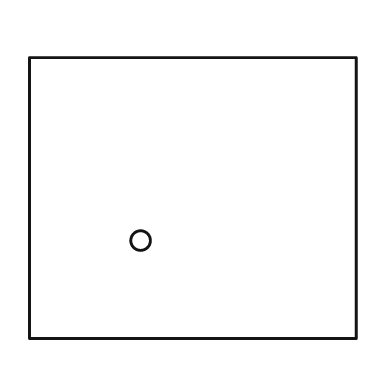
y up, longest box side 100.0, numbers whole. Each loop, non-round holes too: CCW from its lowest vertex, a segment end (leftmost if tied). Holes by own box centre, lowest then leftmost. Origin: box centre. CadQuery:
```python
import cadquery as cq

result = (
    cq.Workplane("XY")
    .moveTo(-50.0, -43.0)
    .lineTo(50.0, -43.0)
    .lineTo(50.0, 43.0)
    .lineTo(-50.0, 43.0)
    .close()
    .moveTo(-16.0, -13.0)
    .circle(3.0)
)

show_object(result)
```